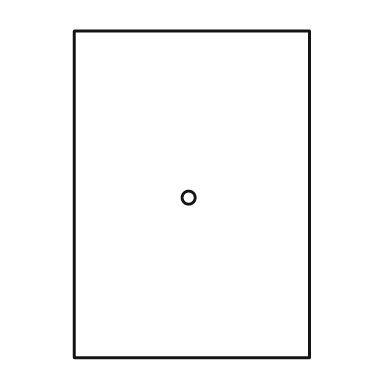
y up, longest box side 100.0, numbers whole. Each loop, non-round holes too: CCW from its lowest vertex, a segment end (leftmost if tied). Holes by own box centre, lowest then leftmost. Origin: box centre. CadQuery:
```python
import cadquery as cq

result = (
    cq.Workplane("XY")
    .moveTo(-36.0, -50.0)
    .lineTo(36.0, -50.0)
    .lineTo(36.0, 50.0)
    .lineTo(-36.0, 50.0)
    .close()
    .moveTo(-1.0, -1.0)
    .circle(2.0)
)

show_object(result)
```